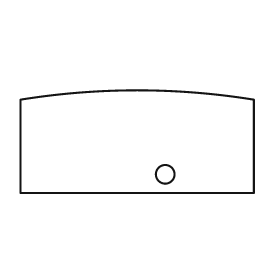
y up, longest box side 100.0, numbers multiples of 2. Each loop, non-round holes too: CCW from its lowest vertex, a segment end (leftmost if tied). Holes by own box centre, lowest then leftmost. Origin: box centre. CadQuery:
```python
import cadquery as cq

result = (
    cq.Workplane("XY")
    .moveTo(-50.0, -22.0)
    .lineTo(50.0, -22.0)
    .lineTo(50.0, 18.0)
    .threePointArc((0.0, 22.0), (-50.0, 18.0))
    .close()
    .moveTo(12.0, -14.0)
    .circle(4.0)
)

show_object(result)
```